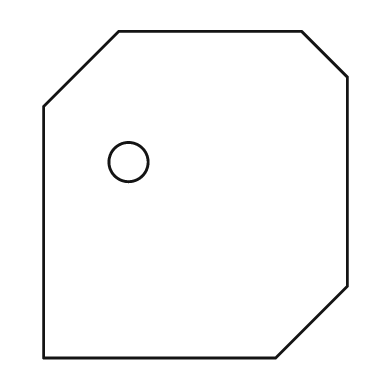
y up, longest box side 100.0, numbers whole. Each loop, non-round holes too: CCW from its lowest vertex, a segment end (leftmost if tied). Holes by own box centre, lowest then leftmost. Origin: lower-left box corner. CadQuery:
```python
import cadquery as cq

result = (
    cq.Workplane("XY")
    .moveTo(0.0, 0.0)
    .lineTo(71.0, 0.0)
    .lineTo(93.0, 22.0)
    .lineTo(93.0, 86.0)
    .lineTo(79.0, 100.0)
    .lineTo(23.0, 100.0)
    .lineTo(0.0, 77.0)
    .close()
    .moveTo(26.0, 60.0)
    .circle(6.0)
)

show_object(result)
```